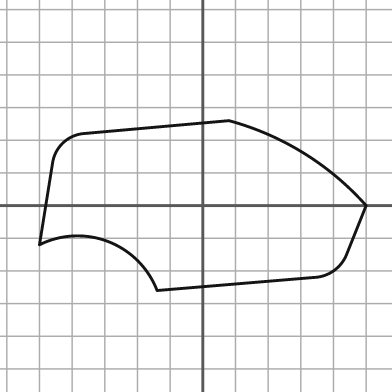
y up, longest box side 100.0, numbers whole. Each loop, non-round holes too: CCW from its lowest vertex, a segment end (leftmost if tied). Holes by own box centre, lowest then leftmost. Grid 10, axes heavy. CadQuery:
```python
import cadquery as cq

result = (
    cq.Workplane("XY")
    .moveTo(-14.0, -26.0)
    .lineTo(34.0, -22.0)
    .threePointArc((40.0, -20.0), (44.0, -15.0))
    .lineTo(50.0, 0.0)
    .threePointArc((31.0, 16.0), (8.0, 26.0))
    .lineTo(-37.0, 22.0)
    .threePointArc((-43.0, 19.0), (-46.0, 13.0))
    .lineTo(-50.0, -12.0)
    .threePointArc((-29.0, -11.0), (-14.0, -26.0))
    .close()
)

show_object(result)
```